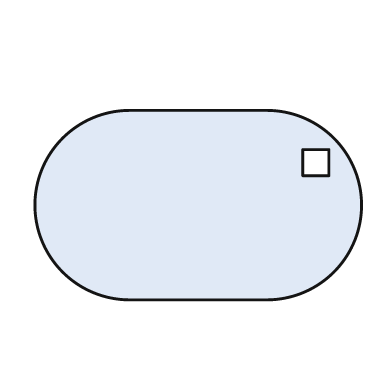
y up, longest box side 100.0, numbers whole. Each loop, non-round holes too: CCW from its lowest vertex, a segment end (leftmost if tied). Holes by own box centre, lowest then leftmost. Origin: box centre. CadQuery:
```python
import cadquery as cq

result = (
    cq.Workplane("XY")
    .moveTo(-21.0, -29.0)
    .lineTo(21.0, -29.0)
    .threePointArc((50.0, 0.0), (21.0, 29.0))
    .lineTo(-21.0, 29.0)
    .threePointArc((-50.0, 0.0), (-21.0, -29.0))
    .close()
    .moveTo(32.0, 9.0)
    .lineTo(40.0, 9.0)
    .lineTo(40.0, 17.0)
    .lineTo(32.0, 17.0)
    .close()
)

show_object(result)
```